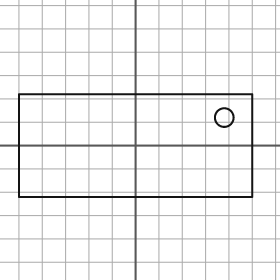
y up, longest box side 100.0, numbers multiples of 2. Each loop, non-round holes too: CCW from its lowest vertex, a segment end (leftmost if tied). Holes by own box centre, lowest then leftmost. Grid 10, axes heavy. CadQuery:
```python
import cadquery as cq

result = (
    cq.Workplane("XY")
    .moveTo(-50.0, -22.0)
    .lineTo(50.0, -22.0)
    .lineTo(50.0, 22.0)
    .lineTo(-50.0, 22.0)
    .close()
    .moveTo(38.0, 12.0)
    .circle(4.0)
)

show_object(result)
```